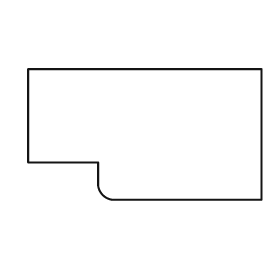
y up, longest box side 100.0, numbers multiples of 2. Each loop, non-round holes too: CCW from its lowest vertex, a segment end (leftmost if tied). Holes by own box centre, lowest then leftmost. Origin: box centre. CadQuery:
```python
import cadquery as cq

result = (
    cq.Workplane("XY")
    .moveTo(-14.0, -28.0)
    .lineTo(50.0, -28.0)
    .lineTo(50.0, 28.0)
    .lineTo(-50.0, 28.0)
    .lineTo(-50.0, -12.0)
    .lineTo(-20.0, -12.0)
    .lineTo(-20.0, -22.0)
    .threePointArc((-18.0, -26.0), (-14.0, -28.0))
    .close()
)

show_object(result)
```